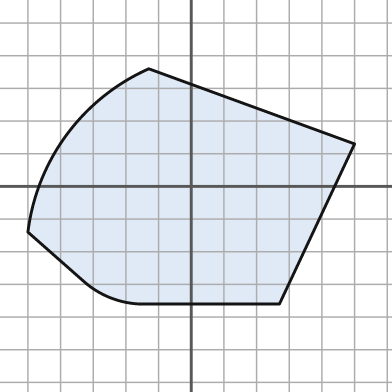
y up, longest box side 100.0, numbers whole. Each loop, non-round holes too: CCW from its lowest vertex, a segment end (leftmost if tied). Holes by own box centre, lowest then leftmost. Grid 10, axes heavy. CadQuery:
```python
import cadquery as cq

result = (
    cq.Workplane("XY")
    .moveTo(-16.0, -36.0)
    .lineTo(27.0, -36.0)
    .lineTo(50.0, 13.0)
    .lineTo(-13.0, 36.0)
    .threePointArc((-38.0, 16.0), (-50.0, -14.0))
    .lineTo(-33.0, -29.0)
    .threePointArc((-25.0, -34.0), (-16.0, -36.0))
    .close()
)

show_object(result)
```